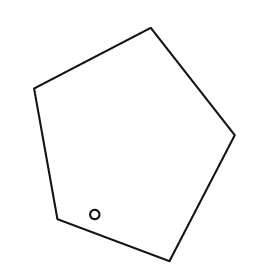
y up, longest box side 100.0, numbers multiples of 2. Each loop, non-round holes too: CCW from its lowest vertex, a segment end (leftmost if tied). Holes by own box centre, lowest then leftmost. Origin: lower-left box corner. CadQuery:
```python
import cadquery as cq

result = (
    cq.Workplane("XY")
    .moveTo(58.0, 0.0)
    .lineTo(86.0, 54.0)
    .lineTo(50.0, 100.0)
    .lineTo(0.0, 74.0)
    .lineTo(10.0, 18.0)
    .close()
    .moveTo(26.0, 20.0)
    .circle(2.0)
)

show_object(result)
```